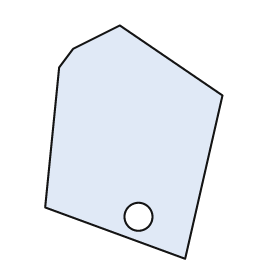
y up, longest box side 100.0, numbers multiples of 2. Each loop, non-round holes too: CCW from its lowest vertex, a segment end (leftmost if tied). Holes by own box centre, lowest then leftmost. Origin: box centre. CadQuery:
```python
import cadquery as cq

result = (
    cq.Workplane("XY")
    .moveTo(22.0, -50.0)
    .lineTo(38.0, 20.0)
    .lineTo(-6.0, 50.0)
    .lineTo(-26.0, 40.0)
    .lineTo(-32.0, 32.0)
    .lineTo(-38.0, -28.0)
    .close()
    .moveTo(2.0, -32.0)
    .circle(6.0)
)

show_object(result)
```